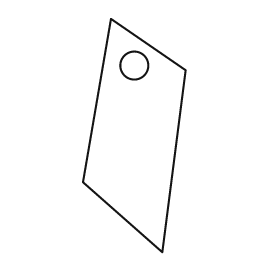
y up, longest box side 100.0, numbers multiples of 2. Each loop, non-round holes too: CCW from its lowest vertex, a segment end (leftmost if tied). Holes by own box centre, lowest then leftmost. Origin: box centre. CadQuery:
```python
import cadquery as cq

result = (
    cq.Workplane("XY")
    .moveTo(12.0, -50.0)
    .lineTo(22.0, 28.0)
    .lineTo(-10.0, 50.0)
    .lineTo(-22.0, -20.0)
    .close()
    .moveTo(0.0, 30.0)
    .circle(6.0)
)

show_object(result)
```